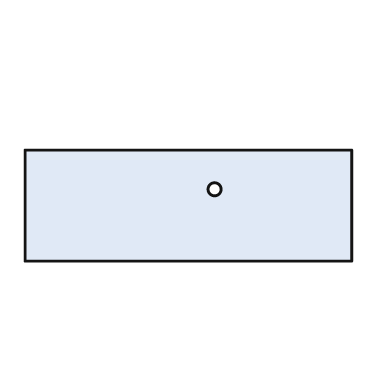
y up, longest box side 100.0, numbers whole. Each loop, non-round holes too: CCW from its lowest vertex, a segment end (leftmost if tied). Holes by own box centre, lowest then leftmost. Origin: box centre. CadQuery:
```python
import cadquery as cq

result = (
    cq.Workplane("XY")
    .moveTo(-50.0, -17.0)
    .lineTo(50.0, -17.0)
    .lineTo(50.0, 17.0)
    .lineTo(-50.0, 17.0)
    .close()
    .moveTo(8.0, 5.0)
    .circle(2.0)
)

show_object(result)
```